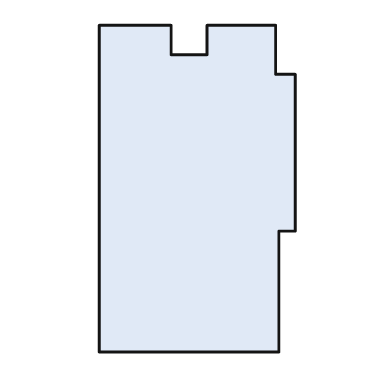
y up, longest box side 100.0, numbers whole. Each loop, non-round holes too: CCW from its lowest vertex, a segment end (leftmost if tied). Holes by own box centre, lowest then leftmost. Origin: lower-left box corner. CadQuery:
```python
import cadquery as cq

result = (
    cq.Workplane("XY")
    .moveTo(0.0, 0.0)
    .lineTo(55.0, 0.0)
    .lineTo(55.0, 37.0)
    .lineTo(60.0, 37.0)
    .lineTo(60.0, 85.0)
    .lineTo(54.0, 85.0)
    .lineTo(54.0, 100.0)
    .lineTo(33.0, 100.0)
    .lineTo(33.0, 91.0)
    .lineTo(22.0, 91.0)
    .lineTo(22.0, 100.0)
    .lineTo(0.0, 100.0)
    .close()
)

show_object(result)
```